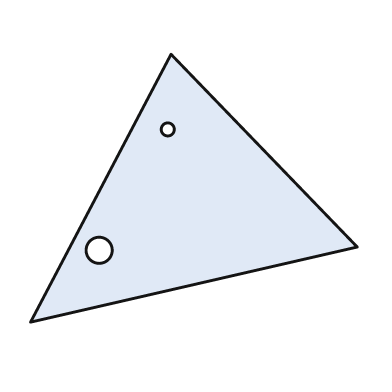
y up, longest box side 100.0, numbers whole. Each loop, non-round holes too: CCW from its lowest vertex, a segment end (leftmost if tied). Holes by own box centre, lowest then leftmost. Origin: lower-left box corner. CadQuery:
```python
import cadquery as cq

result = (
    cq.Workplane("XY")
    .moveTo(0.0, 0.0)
    .lineTo(100.0, 23.0)
    .lineTo(43.0, 82.0)
    .close()
    .moveTo(21.0, 22.0)
    .circle(4.0)
    .moveTo(42.0, 59.0)
    .circle(2.0)
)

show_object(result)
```